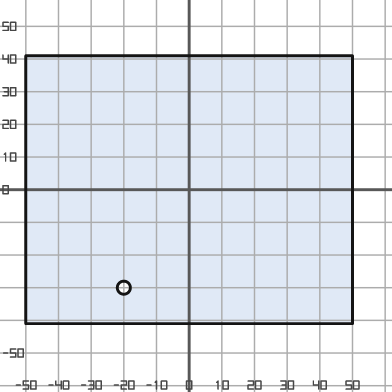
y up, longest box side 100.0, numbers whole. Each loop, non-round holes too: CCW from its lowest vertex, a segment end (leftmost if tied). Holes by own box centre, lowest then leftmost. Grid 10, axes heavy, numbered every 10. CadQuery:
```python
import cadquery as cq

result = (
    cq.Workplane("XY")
    .moveTo(-50.0, -41.0)
    .lineTo(50.0, -41.0)
    .lineTo(50.0, 41.0)
    .lineTo(-50.0, 41.0)
    .close()
    .moveTo(-20.0, -30.0)
    .circle(2.0)
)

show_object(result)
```